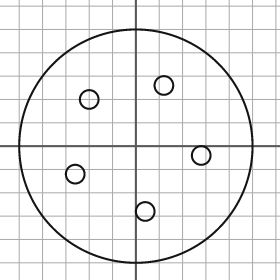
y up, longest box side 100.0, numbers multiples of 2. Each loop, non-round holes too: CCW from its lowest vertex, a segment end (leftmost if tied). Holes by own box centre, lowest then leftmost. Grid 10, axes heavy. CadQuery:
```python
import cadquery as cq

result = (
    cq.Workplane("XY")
    .moveTo(0.0, 0.0)
    .circle(50.0)
    .moveTo(4.0, -28.0)
    .circle(4.0)
    .moveTo(-26.0, -12.0)
    .circle(4.0)
    .moveTo(28.0, -4.0)
    .circle(4.0)
    .moveTo(-20.0, 20.0)
    .circle(4.0)
    .moveTo(12.0, 26.0)
    .circle(4.0)
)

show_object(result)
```